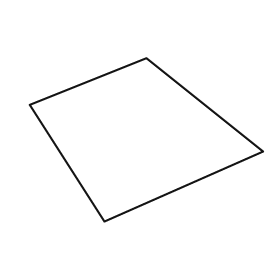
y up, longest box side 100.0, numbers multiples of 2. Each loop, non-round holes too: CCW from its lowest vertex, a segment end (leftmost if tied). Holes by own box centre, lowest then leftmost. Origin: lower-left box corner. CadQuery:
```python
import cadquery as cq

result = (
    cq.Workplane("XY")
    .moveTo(32.0, 0.0)
    .lineTo(100.0, 30.0)
    .lineTo(50.0, 70.0)
    .lineTo(0.0, 50.0)
    .close()
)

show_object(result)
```